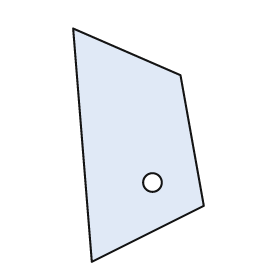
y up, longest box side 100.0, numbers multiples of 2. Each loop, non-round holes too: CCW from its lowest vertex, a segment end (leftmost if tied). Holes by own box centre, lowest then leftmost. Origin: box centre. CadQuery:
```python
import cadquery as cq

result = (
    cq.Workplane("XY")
    .moveTo(-20.0, -50.0)
    .lineTo(28.0, -26.0)
    .lineTo(18.0, 30.0)
    .lineTo(-28.0, 50.0)
    .close()
    .moveTo(6.0, -16.0)
    .circle(4.0)
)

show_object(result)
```